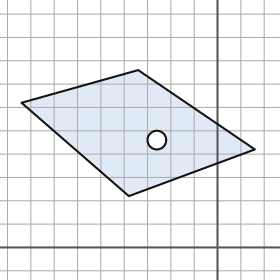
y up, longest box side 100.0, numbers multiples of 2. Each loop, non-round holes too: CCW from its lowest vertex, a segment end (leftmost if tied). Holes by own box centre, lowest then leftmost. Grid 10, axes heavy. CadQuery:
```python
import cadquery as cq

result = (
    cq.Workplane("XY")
    .moveTo(-38.0, 22.0)
    .lineTo(16.0, 42.0)
    .lineTo(-34.0, 76.0)
    .lineTo(-84.0, 62.0)
    .close()
    .moveTo(-26.0, 46.0)
    .circle(4.0)
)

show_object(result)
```